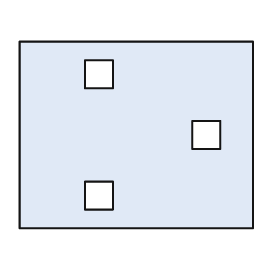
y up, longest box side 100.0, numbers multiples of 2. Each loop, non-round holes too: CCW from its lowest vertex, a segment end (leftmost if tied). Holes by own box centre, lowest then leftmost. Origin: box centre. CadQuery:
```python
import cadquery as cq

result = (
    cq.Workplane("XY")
    .moveTo(-50.0, -40.0)
    .lineTo(50.0, -40.0)
    .lineTo(50.0, 40.0)
    .lineTo(-50.0, 40.0)
    .close()
    .moveTo(-22.0, -32.0)
    .lineTo(-10.0, -32.0)
    .lineTo(-10.0, -20.0)
    .lineTo(-22.0, -20.0)
    .close()
    .moveTo(24.0, -6.0)
    .lineTo(36.0, -6.0)
    .lineTo(36.0, 6.0)
    .lineTo(24.0, 6.0)
    .close()
    .moveTo(-22.0, 20.0)
    .lineTo(-10.0, 20.0)
    .lineTo(-10.0, 32.0)
    .lineTo(-22.0, 32.0)
    .close()
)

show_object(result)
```